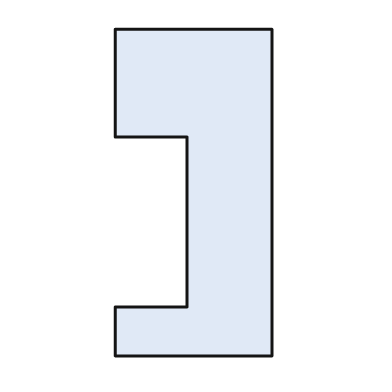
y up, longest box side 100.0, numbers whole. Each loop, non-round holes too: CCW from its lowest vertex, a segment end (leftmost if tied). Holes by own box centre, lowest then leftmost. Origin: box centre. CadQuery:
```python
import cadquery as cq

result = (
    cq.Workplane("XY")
    .moveTo(-24.0, -50.0)
    .lineTo(24.0, -50.0)
    .lineTo(24.0, 50.0)
    .lineTo(-24.0, 50.0)
    .lineTo(-24.0, 17.0)
    .lineTo(-2.0, 17.0)
    .lineTo(-2.0, -35.0)
    .lineTo(-24.0, -35.0)
    .close()
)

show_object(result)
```